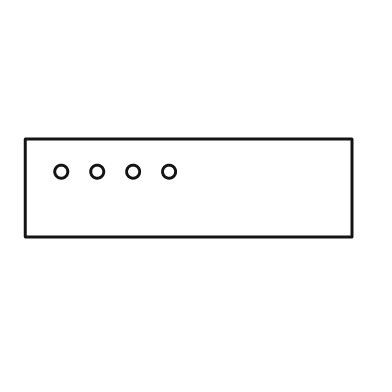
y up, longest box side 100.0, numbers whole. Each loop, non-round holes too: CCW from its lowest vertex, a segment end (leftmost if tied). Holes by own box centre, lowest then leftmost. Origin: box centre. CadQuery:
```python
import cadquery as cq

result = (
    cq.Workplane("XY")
    .moveTo(-50.0, -15.0)
    .lineTo(50.0, -15.0)
    .lineTo(50.0, 15.0)
    .lineTo(-50.0, 15.0)
    .close()
    .moveTo(-39.0, 5.0)
    .circle(2.0)
    .moveTo(-28.0, 5.0)
    .circle(2.0)
    .moveTo(-17.0, 5.0)
    .circle(2.0)
    .moveTo(-6.0, 5.0)
    .circle(2.0)
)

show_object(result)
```